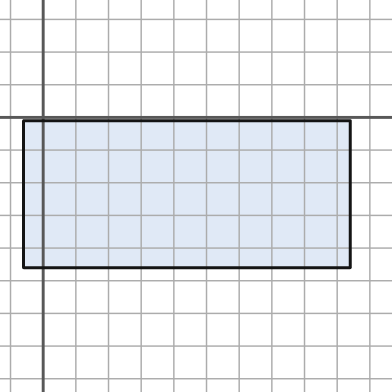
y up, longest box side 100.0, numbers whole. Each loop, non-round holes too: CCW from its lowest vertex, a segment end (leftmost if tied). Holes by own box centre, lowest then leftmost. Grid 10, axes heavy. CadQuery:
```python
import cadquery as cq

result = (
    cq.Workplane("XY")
    .moveTo(-6.0, -46.0)
    .lineTo(94.0, -46.0)
    .lineTo(94.0, -1.0)
    .lineTo(-6.0, -1.0)
    .close()
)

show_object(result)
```